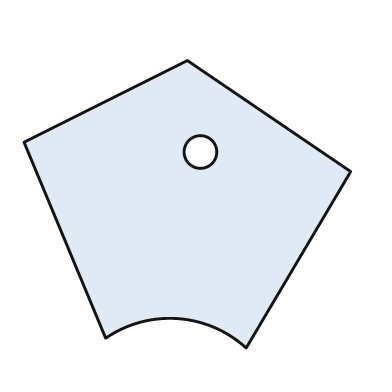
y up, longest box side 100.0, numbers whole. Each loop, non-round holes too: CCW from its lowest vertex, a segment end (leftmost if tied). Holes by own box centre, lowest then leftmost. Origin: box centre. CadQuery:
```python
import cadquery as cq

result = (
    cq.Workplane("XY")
    .moveTo(18.0, -44.0)
    .lineTo(50.0, 10.0)
    .lineTo(0.0, 44.0)
    .lineTo(-50.0, 19.0)
    .lineTo(-25.0, -41.0)
    .threePointArc((-3.0, -35.0), (18.0, -44.0))
    .close()
    .moveTo(4.0, 16.0)
    .circle(5.0)
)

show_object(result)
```